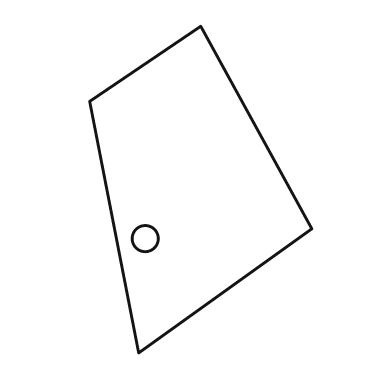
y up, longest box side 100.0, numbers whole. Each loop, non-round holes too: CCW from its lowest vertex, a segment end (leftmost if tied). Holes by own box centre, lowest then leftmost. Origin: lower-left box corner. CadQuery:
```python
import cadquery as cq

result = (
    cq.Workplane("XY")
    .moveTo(15.0, 0.0)
    .lineTo(68.0, 38.0)
    .lineTo(34.0, 100.0)
    .lineTo(0.0, 77.0)
    .close()
    .moveTo(17.0, 35.0)
    .circle(4.0)
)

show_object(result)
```